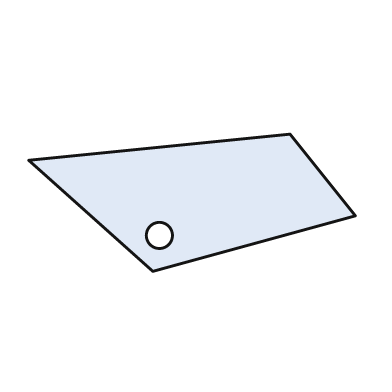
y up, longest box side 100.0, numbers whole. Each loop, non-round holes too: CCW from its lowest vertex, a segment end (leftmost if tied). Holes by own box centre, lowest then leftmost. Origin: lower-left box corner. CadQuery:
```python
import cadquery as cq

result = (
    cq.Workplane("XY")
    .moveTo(38.0, 0.0)
    .lineTo(100.0, 17.0)
    .lineTo(80.0, 42.0)
    .lineTo(0.0, 34.0)
    .close()
    .moveTo(40.0, 11.0)
    .circle(4.0)
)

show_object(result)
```